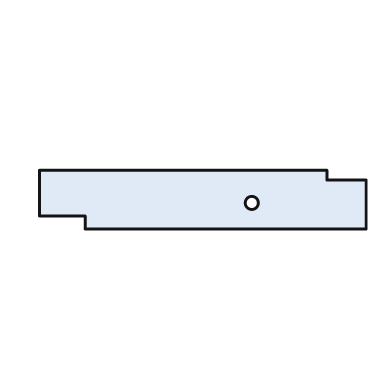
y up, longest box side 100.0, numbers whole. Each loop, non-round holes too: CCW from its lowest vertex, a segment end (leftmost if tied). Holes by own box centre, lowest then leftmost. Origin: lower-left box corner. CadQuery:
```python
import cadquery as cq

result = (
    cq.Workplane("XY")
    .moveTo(14.0, 0.0)
    .lineTo(100.0, 0.0)
    .lineTo(100.0, 15.0)
    .lineTo(88.0, 15.0)
    .lineTo(88.0, 18.0)
    .lineTo(0.0, 18.0)
    .lineTo(0.0, 4.0)
    .lineTo(14.0, 4.0)
    .close()
    .moveTo(65.0, 8.0)
    .circle(2.0)
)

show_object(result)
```